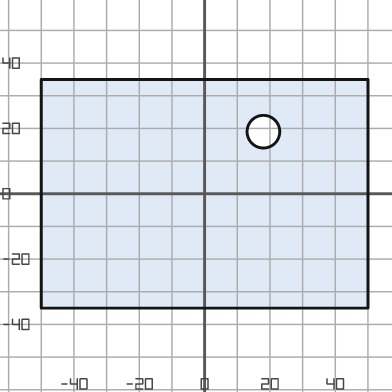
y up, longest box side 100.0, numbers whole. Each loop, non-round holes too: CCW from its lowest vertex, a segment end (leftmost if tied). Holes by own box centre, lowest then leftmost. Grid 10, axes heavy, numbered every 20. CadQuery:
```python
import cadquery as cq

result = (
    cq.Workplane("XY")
    .moveTo(-50.0, -35.0)
    .lineTo(50.0, -35.0)
    .lineTo(50.0, 35.0)
    .lineTo(-50.0, 35.0)
    .close()
    .moveTo(18.0, 19.0)
    .circle(5.0)
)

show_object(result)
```